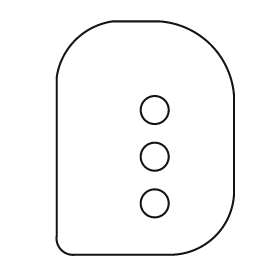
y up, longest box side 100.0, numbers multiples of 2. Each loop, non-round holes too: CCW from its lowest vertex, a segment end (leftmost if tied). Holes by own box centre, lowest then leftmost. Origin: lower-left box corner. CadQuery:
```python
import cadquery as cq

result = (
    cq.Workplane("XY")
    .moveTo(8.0, 0.0)
    .lineTo(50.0, 0.0)
    .threePointArc((68.0, 8.0), (76.0, 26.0))
    .lineTo(76.0, 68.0)
    .threePointArc((66.0, 90.0), (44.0, 100.0))
    .lineTo(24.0, 100.0)
    .threePointArc((8.0, 92.0), (0.0, 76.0))
    .lineTo(0.0, 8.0)
    .threePointArc((2.0, 2.0), (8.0, 0.0))
    .close()
    .moveTo(42.0, 22.0)
    .circle(6.0)
    .moveTo(42.0, 42.0)
    .circle(6.0)
    .moveTo(42.0, 62.0)
    .circle(6.0)
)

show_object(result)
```